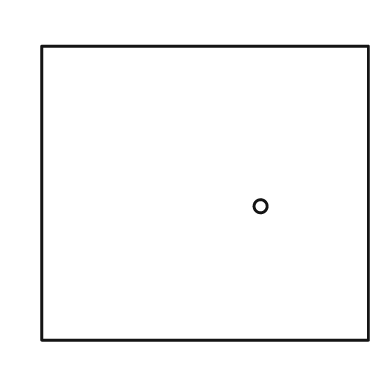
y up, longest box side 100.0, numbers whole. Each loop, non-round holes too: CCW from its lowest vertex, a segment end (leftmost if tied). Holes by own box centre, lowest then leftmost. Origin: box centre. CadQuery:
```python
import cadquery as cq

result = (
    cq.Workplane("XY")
    .moveTo(-50.0, -45.0)
    .lineTo(50.0, -45.0)
    .lineTo(50.0, 45.0)
    .lineTo(-50.0, 45.0)
    .close()
    .moveTo(17.0, -4.0)
    .circle(2.0)
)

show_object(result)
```